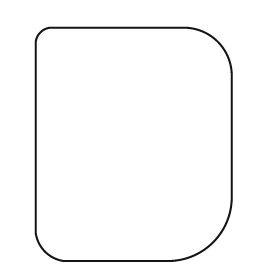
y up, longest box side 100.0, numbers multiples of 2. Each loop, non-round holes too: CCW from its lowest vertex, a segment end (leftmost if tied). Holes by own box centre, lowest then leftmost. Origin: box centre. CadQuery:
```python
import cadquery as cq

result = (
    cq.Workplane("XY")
    .moveTo(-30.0, -50.0)
    .lineTo(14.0, -50.0)
    .threePointArc((34.0, -42.0), (42.0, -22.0))
    .lineTo(42.0, 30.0)
    .threePointArc((36.0, 44.0), (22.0, 50.0))
    .lineTo(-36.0, 50.0)
    .threePointArc((-40.0, 48.0), (-42.0, 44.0))
    .lineTo(-42.0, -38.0)
    .threePointArc((-38.0, -46.0), (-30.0, -50.0))
    .close()
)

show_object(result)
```